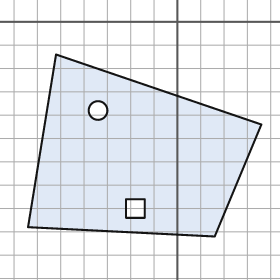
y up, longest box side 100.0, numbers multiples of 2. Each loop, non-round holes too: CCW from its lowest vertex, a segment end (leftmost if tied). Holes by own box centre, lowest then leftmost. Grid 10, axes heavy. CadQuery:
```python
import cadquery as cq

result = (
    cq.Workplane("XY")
    .moveTo(16.0, -92.0)
    .lineTo(36.0, -44.0)
    .lineTo(-52.0, -14.0)
    .lineTo(-64.0, -88.0)
    .close()
    .moveTo(-22.0, -84.0)
    .lineTo(-14.0, -84.0)
    .lineTo(-14.0, -76.0)
    .lineTo(-22.0, -76.0)
    .close()
    .moveTo(-34.0, -38.0)
    .circle(4.0)
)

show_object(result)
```